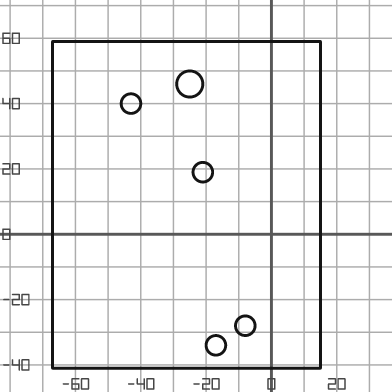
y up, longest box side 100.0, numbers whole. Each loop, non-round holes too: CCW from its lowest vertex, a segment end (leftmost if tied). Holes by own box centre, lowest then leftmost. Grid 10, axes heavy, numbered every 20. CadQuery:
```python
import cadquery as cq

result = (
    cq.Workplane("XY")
    .moveTo(-67.0, -41.0)
    .lineTo(15.0, -41.0)
    .lineTo(15.0, 59.0)
    .lineTo(-67.0, 59.0)
    .close()
    .moveTo(-17.0, -34.0)
    .circle(3.0)
    .moveTo(-8.0, -28.0)
    .circle(3.0)
    .moveTo(-21.0, 19.0)
    .circle(3.0)
    .moveTo(-43.0, 40.0)
    .circle(3.0)
    .moveTo(-25.0, 46.0)
    .circle(4.0)
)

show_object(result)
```